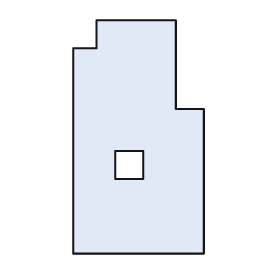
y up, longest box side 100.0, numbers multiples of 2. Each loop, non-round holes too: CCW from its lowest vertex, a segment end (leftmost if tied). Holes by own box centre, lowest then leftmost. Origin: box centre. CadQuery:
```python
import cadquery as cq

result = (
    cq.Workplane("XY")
    .moveTo(-28.0, -50.0)
    .lineTo(28.0, -50.0)
    .lineTo(28.0, 12.0)
    .lineTo(16.0, 12.0)
    .lineTo(16.0, 50.0)
    .lineTo(-18.0, 50.0)
    .lineTo(-18.0, 38.0)
    .lineTo(-28.0, 38.0)
    .close()
    .moveTo(-10.0, -18.0)
    .lineTo(2.0, -18.0)
    .lineTo(2.0, -6.0)
    .lineTo(-10.0, -6.0)
    .close()
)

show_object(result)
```